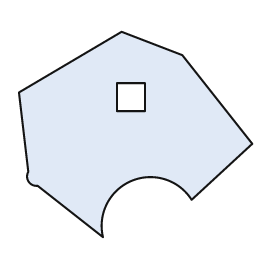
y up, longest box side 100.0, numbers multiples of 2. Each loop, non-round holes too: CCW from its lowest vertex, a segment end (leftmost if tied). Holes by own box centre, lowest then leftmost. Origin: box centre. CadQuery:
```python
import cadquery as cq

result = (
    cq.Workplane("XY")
    .moveTo(-14.0, -44.0)
    .threePointArc((-2.0, -20.0), (24.0, -28.0))
    .lineTo(50.0, -4.0)
    .lineTo(20.0, 34.0)
    .lineTo(-6.0, 44.0)
    .lineTo(-50.0, 18.0)
    .lineTo(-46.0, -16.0)
    .threePointArc((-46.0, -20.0), (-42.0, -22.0))
    .close()
    .moveTo(-8.0, 10.0)
    .lineTo(4.0, 10.0)
    .lineTo(4.0, 22.0)
    .lineTo(-8.0, 22.0)
    .close()
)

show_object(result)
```